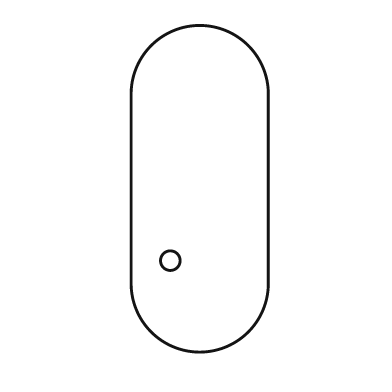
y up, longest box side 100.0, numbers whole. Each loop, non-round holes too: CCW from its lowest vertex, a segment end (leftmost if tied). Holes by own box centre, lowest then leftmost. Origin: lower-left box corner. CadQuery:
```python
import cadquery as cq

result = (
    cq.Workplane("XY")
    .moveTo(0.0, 21.0)
    .threePointArc((21.0, 0.0), (42.0, 21.0))
    .lineTo(42.0, 79.0)
    .threePointArc((21.0, 100.0), (0.0, 79.0))
    .close()
    .moveTo(12.0, 28.0)
    .circle(3.0)
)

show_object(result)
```